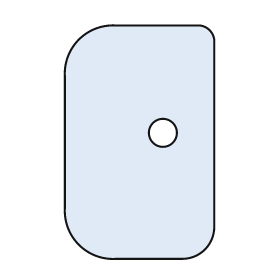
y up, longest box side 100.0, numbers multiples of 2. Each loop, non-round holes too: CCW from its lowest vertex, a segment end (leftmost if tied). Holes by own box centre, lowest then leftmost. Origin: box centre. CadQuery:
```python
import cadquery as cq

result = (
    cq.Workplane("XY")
    .moveTo(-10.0, -50.0)
    .lineTo(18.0, -50.0)
    .threePointArc((28.0, -46.0), (32.0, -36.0))
    .lineTo(32.0, 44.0)
    .threePointArc((30.0, 48.0), (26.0, 50.0))
    .lineTo(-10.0, 50.0)
    .threePointArc((-26.0, 44.0), (-32.0, 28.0))
    .lineTo(-32.0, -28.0)
    .threePointArc((-26.0, -44.0), (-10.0, -50.0))
    .close()
    .moveTo(10.0, 4.0)
    .circle(6.0)
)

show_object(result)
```